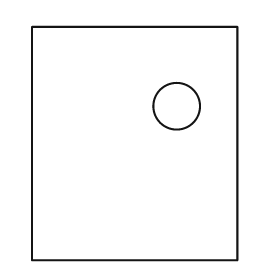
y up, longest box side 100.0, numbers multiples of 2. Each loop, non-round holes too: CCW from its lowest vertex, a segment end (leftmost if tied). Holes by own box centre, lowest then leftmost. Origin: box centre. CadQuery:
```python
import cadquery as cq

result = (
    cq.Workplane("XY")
    .moveTo(-44.0, -50.0)
    .lineTo(44.0, -50.0)
    .lineTo(44.0, 50.0)
    .lineTo(-44.0, 50.0)
    .close()
    .moveTo(18.0, 16.0)
    .circle(10.0)
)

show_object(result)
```